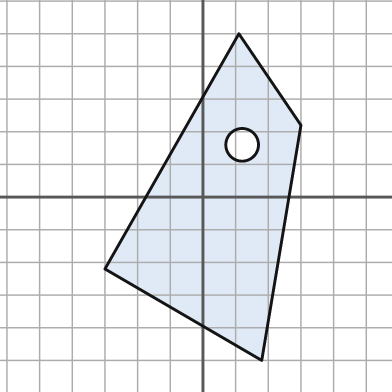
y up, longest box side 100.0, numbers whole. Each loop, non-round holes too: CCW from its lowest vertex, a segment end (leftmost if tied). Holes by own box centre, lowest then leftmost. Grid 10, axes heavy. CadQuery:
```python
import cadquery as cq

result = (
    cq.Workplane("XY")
    .moveTo(18.0, -50.0)
    .lineTo(30.0, 22.0)
    .lineTo(11.0, 50.0)
    .lineTo(-30.0, -22.0)
    .close()
    .moveTo(12.0, 16.0)
    .circle(5.0)
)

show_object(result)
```